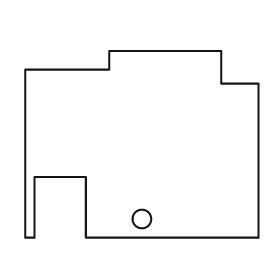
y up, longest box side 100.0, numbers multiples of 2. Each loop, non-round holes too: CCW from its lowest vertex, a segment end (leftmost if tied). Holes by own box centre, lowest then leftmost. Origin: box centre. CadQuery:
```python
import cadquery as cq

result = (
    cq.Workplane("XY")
    .moveTo(-50.0, -40.0)
    .lineTo(-46.0, -40.0)
    .lineTo(-46.0, -14.0)
    .lineTo(-24.0, -14.0)
    .lineTo(-24.0, -40.0)
    .lineTo(50.0, -40.0)
    .lineTo(50.0, 26.0)
    .lineTo(34.0, 26.0)
    .lineTo(34.0, 40.0)
    .lineTo(-14.0, 40.0)
    .lineTo(-14.0, 32.0)
    .lineTo(-50.0, 32.0)
    .close()
    .moveTo(0.0, -32.0)
    .circle(4.0)
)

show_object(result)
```